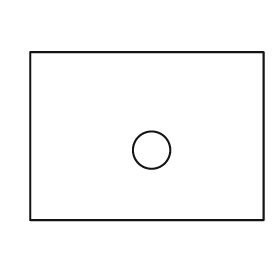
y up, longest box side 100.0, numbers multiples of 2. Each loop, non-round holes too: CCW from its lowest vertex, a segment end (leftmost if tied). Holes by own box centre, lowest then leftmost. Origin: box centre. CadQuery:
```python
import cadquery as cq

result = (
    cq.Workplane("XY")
    .moveTo(-50.0, -36.0)
    .lineTo(50.0, -36.0)
    .lineTo(50.0, 36.0)
    .lineTo(-50.0, 36.0)
    .close()
    .moveTo(2.0, -6.0)
    .circle(8.0)
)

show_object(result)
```